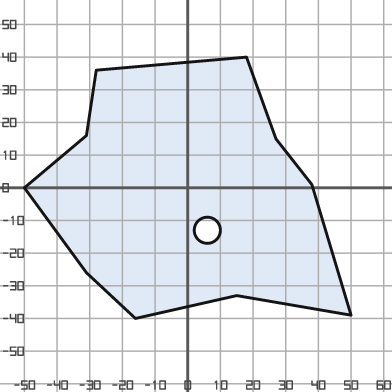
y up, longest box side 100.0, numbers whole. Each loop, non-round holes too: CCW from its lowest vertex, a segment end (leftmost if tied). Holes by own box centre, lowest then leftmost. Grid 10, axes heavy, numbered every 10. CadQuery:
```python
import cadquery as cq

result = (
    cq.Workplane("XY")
    .moveTo(-16.0, -40.0)
    .lineTo(15.0, -33.0)
    .lineTo(50.0, -39.0)
    .lineTo(38.0, 1.0)
    .lineTo(27.0, 15.0)
    .lineTo(18.0, 40.0)
    .lineTo(-28.0, 36.0)
    .lineTo(-31.0, 16.0)
    .lineTo(-50.0, 0.0)
    .lineTo(-31.0, -26.0)
    .close()
    .moveTo(6.0, -13.0)
    .circle(4.0)
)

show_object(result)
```